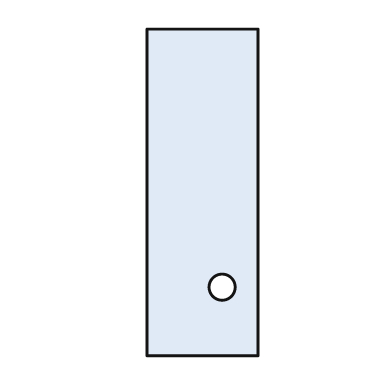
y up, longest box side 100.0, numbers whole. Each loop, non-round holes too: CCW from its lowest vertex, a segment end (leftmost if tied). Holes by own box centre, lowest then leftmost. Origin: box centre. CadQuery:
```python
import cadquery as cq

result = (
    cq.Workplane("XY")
    .moveTo(-17.0, -50.0)
    .lineTo(17.0, -50.0)
    .lineTo(17.0, 50.0)
    .lineTo(-17.0, 50.0)
    .close()
    .moveTo(6.0, -29.0)
    .circle(4.0)
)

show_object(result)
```